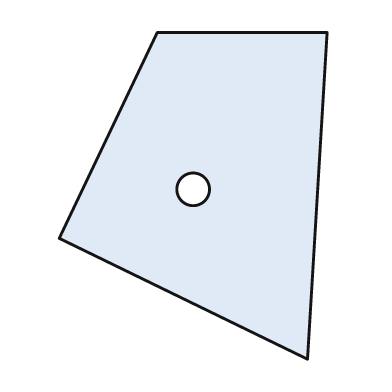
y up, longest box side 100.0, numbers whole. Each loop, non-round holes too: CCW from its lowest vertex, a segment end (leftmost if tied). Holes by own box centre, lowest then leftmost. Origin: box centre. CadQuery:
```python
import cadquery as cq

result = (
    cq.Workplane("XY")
    .moveTo(35.0, -50.0)
    .lineTo(41.0, 50.0)
    .lineTo(-11.0, 50.0)
    .lineTo(-41.0, -13.0)
    .close()
    .moveTo(0.0, 2.0)
    .circle(5.0)
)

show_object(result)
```